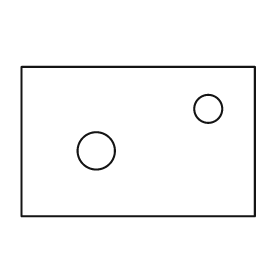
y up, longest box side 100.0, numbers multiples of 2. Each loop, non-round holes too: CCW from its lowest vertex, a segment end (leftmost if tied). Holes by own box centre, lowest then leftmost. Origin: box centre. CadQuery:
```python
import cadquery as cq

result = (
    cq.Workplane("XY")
    .moveTo(-50.0, -32.0)
    .lineTo(50.0, -32.0)
    .lineTo(50.0, 32.0)
    .lineTo(-50.0, 32.0)
    .close()
    .moveTo(-18.0, -4.0)
    .circle(8.0)
    .moveTo(30.0, 14.0)
    .circle(6.0)
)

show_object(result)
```